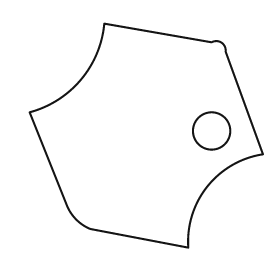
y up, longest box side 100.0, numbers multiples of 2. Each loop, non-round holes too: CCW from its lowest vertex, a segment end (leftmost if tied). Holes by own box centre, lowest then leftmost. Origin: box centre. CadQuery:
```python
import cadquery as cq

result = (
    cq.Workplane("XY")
    .moveTo(18.0, -48.0)
    .threePointArc((26.0, -22.0), (50.0, -8.0))
    .lineTo(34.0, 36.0)
    .threePointArc((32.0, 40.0), (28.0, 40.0))
    .lineTo(-18.0, 48.0)
    .threePointArc((-28.0, 24.0), (-50.0, 10.0))
    .lineTo(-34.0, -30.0)
    .threePointArc((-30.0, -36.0), (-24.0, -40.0))
    .close()
    .moveTo(28.0, 2.0)
    .circle(8.0)
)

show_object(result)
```